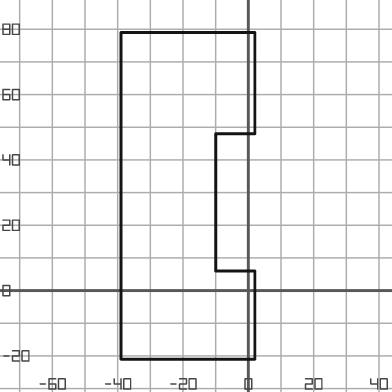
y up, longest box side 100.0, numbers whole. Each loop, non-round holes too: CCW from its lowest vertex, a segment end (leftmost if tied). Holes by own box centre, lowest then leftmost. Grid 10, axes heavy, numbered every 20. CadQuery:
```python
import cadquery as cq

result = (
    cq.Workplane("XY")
    .moveTo(-39.0, -21.0)
    .lineTo(2.0, -21.0)
    .lineTo(2.0, 6.0)
    .lineTo(-10.0, 6.0)
    .lineTo(-10.0, 48.0)
    .lineTo(2.0, 48.0)
    .lineTo(2.0, 79.0)
    .lineTo(-39.0, 79.0)
    .close()
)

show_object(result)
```